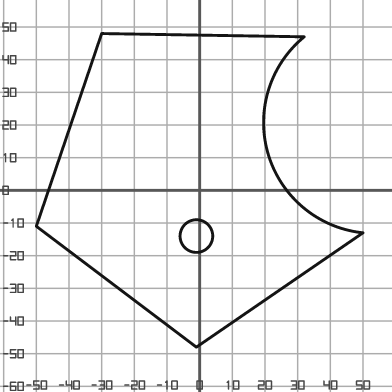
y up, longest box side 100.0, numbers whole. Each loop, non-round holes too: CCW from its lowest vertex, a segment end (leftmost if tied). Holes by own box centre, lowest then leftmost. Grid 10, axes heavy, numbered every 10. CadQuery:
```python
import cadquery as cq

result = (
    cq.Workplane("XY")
    .moveTo(-1.0, -48.0)
    .lineTo(50.0, -13.0)
    .threePointArc((21.0, 11.0), (32.0, 47.0))
    .lineTo(-30.0, 48.0)
    .lineTo(-50.0, -11.0)
    .close()
    .moveTo(-1.0, -14.0)
    .circle(5.0)
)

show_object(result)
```